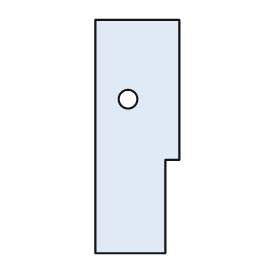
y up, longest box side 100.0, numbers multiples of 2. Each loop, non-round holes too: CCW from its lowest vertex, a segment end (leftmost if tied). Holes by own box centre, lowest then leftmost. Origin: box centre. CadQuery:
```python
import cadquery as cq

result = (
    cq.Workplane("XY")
    .moveTo(-18.0, -50.0)
    .lineTo(12.0, -50.0)
    .lineTo(12.0, -10.0)
    .lineTo(18.0, -10.0)
    .lineTo(18.0, 50.0)
    .lineTo(-18.0, 50.0)
    .close()
    .moveTo(-4.0, 16.0)
    .circle(4.0)
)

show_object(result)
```